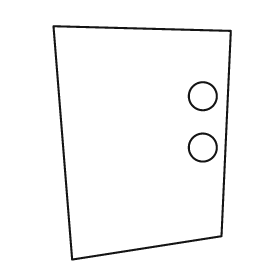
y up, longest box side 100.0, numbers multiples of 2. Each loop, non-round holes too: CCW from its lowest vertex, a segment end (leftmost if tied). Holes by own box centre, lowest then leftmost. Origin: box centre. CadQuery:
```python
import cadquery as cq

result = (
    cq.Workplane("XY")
    .moveTo(-30.0, -50.0)
    .lineTo(34.0, -40.0)
    .lineTo(38.0, 48.0)
    .lineTo(-38.0, 50.0)
    .close()
    .moveTo(26.0, -2.0)
    .circle(6.0)
    .moveTo(26.0, 20.0)
    .circle(6.0)
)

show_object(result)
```